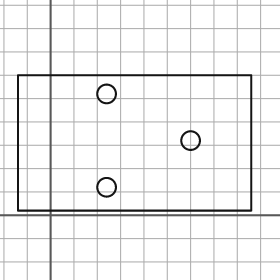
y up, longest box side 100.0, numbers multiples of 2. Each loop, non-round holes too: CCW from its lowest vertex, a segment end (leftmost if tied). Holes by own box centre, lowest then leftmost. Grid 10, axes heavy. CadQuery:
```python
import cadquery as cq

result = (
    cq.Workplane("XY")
    .moveTo(-14.0, 2.0)
    .lineTo(86.0, 2.0)
    .lineTo(86.0, 60.0)
    .lineTo(-14.0, 60.0)
    .close()
    .moveTo(24.0, 12.0)
    .circle(4.0)
    .moveTo(60.0, 32.0)
    .circle(4.0)
    .moveTo(24.0, 52.0)
    .circle(4.0)
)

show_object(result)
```